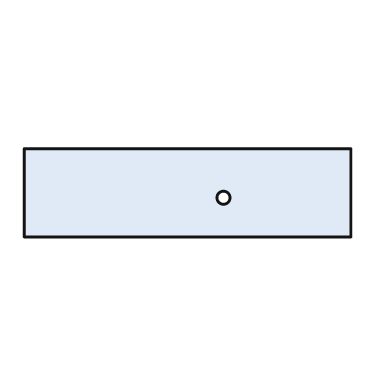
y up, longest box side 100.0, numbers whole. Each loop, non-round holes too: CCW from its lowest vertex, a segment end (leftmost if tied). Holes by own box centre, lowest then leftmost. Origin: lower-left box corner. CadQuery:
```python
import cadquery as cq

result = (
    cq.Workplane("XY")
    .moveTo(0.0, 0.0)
    .lineTo(100.0, 0.0)
    .lineTo(100.0, 27.0)
    .lineTo(0.0, 27.0)
    .close()
    .moveTo(61.0, 12.0)
    .circle(2.0)
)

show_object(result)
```